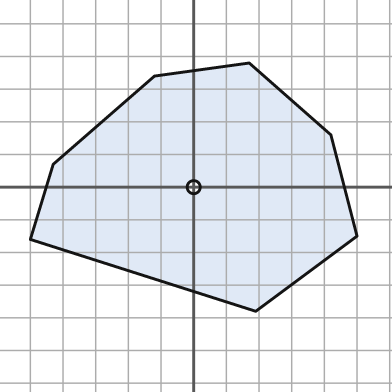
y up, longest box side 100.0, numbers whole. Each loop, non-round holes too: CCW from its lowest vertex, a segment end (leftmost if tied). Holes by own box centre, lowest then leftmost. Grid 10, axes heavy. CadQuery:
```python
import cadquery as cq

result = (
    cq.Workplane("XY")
    .moveTo(19.0, -38.0)
    .lineTo(50.0, -15.0)
    .lineTo(42.0, 16.0)
    .lineTo(17.0, 38.0)
    .lineTo(-12.0, 34.0)
    .lineTo(-43.0, 7.0)
    .lineTo(-50.0, -16.0)
    .close()
    .moveTo(0.0, 0.0)
    .circle(2.0)
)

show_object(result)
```